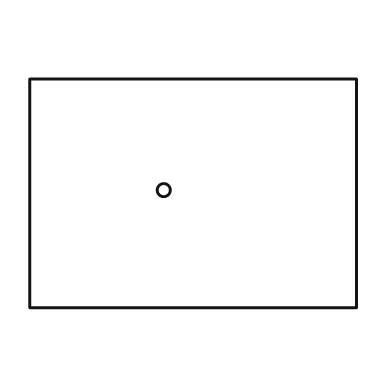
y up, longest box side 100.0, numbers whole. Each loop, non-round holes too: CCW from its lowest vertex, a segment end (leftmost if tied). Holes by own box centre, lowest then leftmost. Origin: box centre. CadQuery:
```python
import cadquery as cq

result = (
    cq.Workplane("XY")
    .moveTo(-50.0, -35.0)
    .lineTo(50.0, -35.0)
    .lineTo(50.0, 35.0)
    .lineTo(-50.0, 35.0)
    .close()
    .moveTo(-9.0, 1.0)
    .circle(2.0)
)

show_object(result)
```